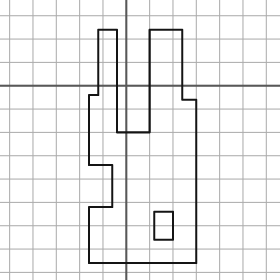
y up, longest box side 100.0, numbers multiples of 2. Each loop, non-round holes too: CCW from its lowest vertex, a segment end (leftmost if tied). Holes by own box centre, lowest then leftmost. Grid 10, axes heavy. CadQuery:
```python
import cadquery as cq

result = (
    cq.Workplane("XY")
    .moveTo(-16.0, -76.0)
    .lineTo(30.0, -76.0)
    .lineTo(30.0, -6.0)
    .lineTo(24.0, -6.0)
    .lineTo(24.0, 24.0)
    .lineTo(10.0, 24.0)
    .lineTo(10.0, -20.0)
    .lineTo(-4.0, -20.0)
    .lineTo(-4.0, 24.0)
    .lineTo(-12.0, 24.0)
    .lineTo(-12.0, -4.0)
    .lineTo(-16.0, -4.0)
    .lineTo(-16.0, -34.0)
    .lineTo(-6.0, -34.0)
    .lineTo(-6.0, -52.0)
    .lineTo(-16.0, -52.0)
    .close()
    .moveTo(12.0, -66.0)
    .lineTo(20.0, -66.0)
    .lineTo(20.0, -54.0)
    .lineTo(12.0, -54.0)
    .close()
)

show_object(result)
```